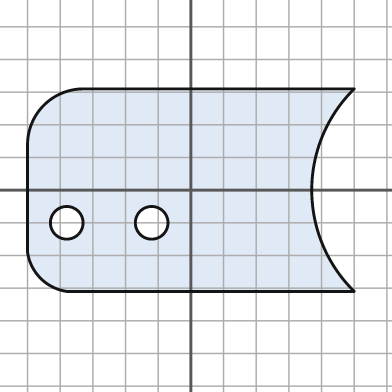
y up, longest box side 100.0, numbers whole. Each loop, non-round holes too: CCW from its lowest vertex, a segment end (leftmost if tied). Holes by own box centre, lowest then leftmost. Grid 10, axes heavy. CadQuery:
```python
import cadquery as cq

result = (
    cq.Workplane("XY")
    .moveTo(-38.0, -31.0)
    .lineTo(50.0, -31.0)
    .threePointArc((37.0, 0.0), (50.0, 31.0))
    .lineTo(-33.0, 31.0)
    .threePointArc((-45.0, 26.0), (-50.0, 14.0))
    .lineTo(-50.0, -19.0)
    .threePointArc((-46.0, -27.0), (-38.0, -31.0))
    .close()
    .moveTo(-38.0, -10.0)
    .circle(5.0)
    .moveTo(-12.0, -10.0)
    .circle(5.0)
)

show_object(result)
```